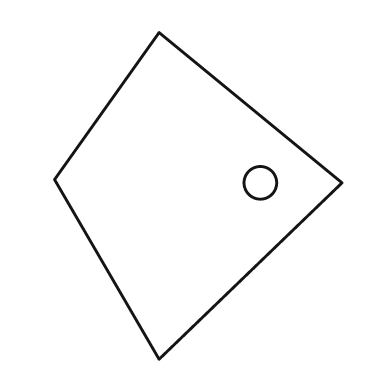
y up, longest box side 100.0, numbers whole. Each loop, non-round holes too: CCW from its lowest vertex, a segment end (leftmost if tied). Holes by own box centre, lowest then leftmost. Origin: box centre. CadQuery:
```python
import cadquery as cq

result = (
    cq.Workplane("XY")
    .moveTo(-12.0, -50.0)
    .lineTo(44.0, 4.0)
    .lineTo(-12.0, 50.0)
    .lineTo(-44.0, 5.0)
    .close()
    .moveTo(19.0, 4.0)
    .circle(5.0)
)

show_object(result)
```